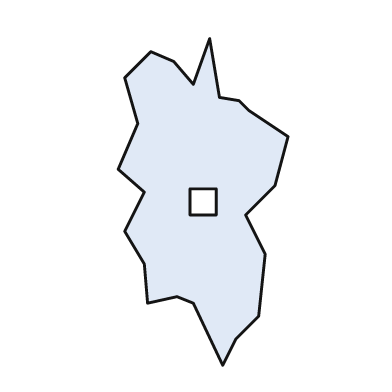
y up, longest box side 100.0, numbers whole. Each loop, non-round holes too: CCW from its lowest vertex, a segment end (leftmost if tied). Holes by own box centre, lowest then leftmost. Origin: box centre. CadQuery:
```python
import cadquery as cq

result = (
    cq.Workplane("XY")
    .moveTo(6.0, -50.0)
    .lineTo(10.0, -42.0)
    .lineTo(17.0, -35.0)
    .lineTo(19.0, -16.0)
    .lineTo(13.0, -4.0)
    .lineTo(22.0, 5.0)
    .lineTo(26.0, 20.0)
    .lineTo(14.0, 28.0)
    .lineTo(11.0, 31.0)
    .lineTo(5.0, 32.0)
    .lineTo(2.0, 50.0)
    .lineTo(-3.0, 36.0)
    .lineTo(-9.0, 43.0)
    .lineTo(-16.0, 46.0)
    .lineTo(-24.0, 38.0)
    .lineTo(-20.0, 24.0)
    .lineTo(-26.0, 10.0)
    .lineTo(-18.0, 3.0)
    .lineTo(-24.0, -9.0)
    .lineTo(-18.0, -19.0)
    .lineTo(-17.0, -31.0)
    .lineTo(-8.0, -29.0)
    .lineTo(-3.0, -31.0)
    .close()
    .moveTo(-4.0, -4.0)
    .lineTo(4.0, -4.0)
    .lineTo(4.0, 4.0)
    .lineTo(-4.0, 4.0)
    .close()
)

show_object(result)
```